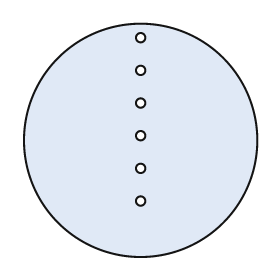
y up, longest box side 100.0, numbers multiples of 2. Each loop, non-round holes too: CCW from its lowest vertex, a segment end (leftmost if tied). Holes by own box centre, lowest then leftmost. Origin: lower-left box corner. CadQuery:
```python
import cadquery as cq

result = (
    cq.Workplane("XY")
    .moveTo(50.0, 50.0)
    .circle(50.0)
    .moveTo(50.0, 24.0)
    .circle(2.0)
    .moveTo(50.0, 38.0)
    .circle(2.0)
    .moveTo(50.0, 52.0)
    .circle(2.0)
    .moveTo(50.0, 66.0)
    .circle(2.0)
    .moveTo(50.0, 80.0)
    .circle(2.0)
    .moveTo(50.0, 94.0)
    .circle(2.0)
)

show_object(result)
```